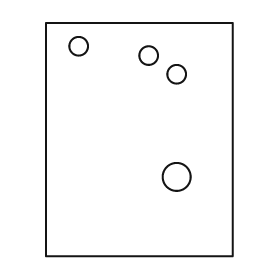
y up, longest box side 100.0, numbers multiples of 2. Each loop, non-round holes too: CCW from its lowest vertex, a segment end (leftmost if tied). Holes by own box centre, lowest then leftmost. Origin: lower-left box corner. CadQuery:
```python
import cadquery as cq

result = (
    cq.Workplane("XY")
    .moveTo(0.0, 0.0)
    .lineTo(80.0, 0.0)
    .lineTo(80.0, 100.0)
    .lineTo(0.0, 100.0)
    .close()
    .moveTo(56.0, 34.0)
    .circle(6.0)
    .moveTo(56.0, 78.0)
    .circle(4.0)
    .moveTo(44.0, 86.0)
    .circle(4.0)
    .moveTo(14.0, 90.0)
    .circle(4.0)
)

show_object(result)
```